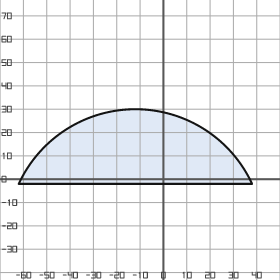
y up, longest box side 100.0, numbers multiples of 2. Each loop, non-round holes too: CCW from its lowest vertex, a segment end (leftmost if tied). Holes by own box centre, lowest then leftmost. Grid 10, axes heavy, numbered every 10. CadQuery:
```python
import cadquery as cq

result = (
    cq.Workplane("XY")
    .moveTo(-62.0, -2.0)
    .lineTo(38.0, -2.0)
    .threePointArc((-12.0, 30.0), (-62.0, -2.0))
    .close()
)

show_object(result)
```